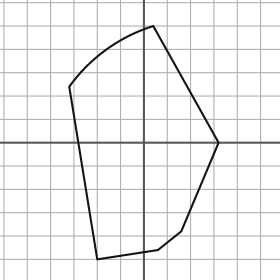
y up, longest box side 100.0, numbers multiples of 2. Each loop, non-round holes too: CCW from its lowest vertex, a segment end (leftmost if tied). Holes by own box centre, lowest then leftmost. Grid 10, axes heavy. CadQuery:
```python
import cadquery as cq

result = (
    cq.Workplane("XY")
    .moveTo(-20.0, -50.0)
    .lineTo(6.0, -46.0)
    .lineTo(16.0, -38.0)
    .lineTo(32.0, 0.0)
    .lineTo(4.0, 50.0)
    .threePointArc((-16.0, 40.0), (-32.0, 24.0))
    .close()
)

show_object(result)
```